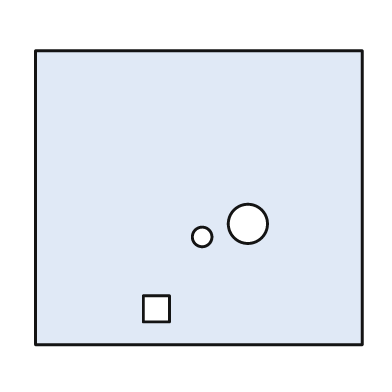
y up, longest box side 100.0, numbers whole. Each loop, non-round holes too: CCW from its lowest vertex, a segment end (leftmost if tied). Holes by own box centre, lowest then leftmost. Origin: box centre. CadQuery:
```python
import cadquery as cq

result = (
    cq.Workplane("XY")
    .moveTo(-50.0, -45.0)
    .lineTo(50.0, -45.0)
    .lineTo(50.0, 45.0)
    .lineTo(-50.0, 45.0)
    .close()
    .moveTo(-17.0, -38.0)
    .lineTo(-9.0, -38.0)
    .lineTo(-9.0, -30.0)
    .lineTo(-17.0, -30.0)
    .close()
    .moveTo(1.0, -12.0)
    .circle(3.0)
    .moveTo(15.0, -8.0)
    .circle(6.0)
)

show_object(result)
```